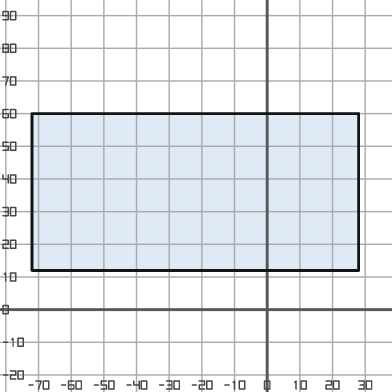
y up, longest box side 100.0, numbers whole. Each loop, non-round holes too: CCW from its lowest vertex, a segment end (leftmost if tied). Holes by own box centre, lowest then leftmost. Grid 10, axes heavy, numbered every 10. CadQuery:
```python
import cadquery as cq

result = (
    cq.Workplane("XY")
    .moveTo(-72.0, 12.0)
    .lineTo(28.0, 12.0)
    .lineTo(28.0, 60.0)
    .lineTo(-72.0, 60.0)
    .close()
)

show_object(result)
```